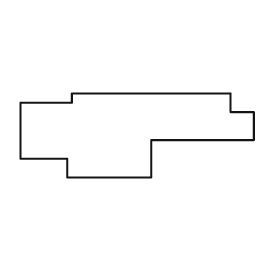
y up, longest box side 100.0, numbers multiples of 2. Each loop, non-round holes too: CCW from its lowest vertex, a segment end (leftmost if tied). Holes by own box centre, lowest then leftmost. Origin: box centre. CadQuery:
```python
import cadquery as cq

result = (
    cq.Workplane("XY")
    .moveTo(-30.0, -18.0)
    .lineTo(6.0, -18.0)
    .lineTo(6.0, -2.0)
    .lineTo(50.0, -2.0)
    .lineTo(50.0, 10.0)
    .lineTo(40.0, 10.0)
    .lineTo(40.0, 18.0)
    .lineTo(-28.0, 18.0)
    .lineTo(-28.0, 14.0)
    .lineTo(-50.0, 14.0)
    .lineTo(-50.0, -10.0)
    .lineTo(-30.0, -10.0)
    .close()
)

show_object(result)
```